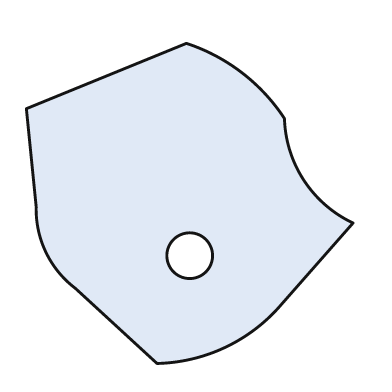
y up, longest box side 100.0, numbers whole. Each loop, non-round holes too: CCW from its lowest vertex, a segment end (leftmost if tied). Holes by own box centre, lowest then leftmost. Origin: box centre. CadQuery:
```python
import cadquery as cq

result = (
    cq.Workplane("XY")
    .moveTo(-10.0, -49.0)
    .threePointArc((11.0, -44.0), (28.0, -31.0))
    .lineTo(50.0, -6.0)
    .threePointArc((35.0, 7.0), (29.0, 26.0))
    .threePointArc((16.0, 40.0), (-1.0, 49.0))
    .lineTo(-50.0, 29.0)
    .lineTo(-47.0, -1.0)
    .threePointArc((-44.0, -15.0), (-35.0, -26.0))
    .close()
    .moveTo(0.0, -16.0)
    .circle(7.0)
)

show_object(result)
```